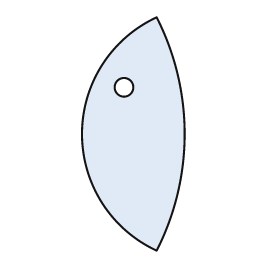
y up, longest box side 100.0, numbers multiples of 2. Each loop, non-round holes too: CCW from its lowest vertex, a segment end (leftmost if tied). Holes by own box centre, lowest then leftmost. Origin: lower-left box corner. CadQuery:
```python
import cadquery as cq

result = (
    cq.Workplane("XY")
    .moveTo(32.0, 0.0)
    .threePointArc((44.0, 50.0), (32.0, 100.0))
    .threePointArc((0.0, 50.0), (32.0, 0.0))
    .close()
    .moveTo(18.0, 70.0)
    .circle(4.0)
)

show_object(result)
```